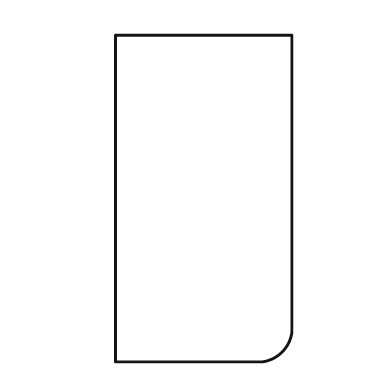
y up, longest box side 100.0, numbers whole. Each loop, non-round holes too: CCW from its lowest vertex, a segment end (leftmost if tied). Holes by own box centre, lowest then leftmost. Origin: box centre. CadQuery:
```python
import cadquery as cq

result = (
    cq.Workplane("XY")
    .moveTo(-27.0, -50.0)
    .lineTo(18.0, -50.0)
    .threePointArc((24.0, -47.0), (27.0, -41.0))
    .lineTo(27.0, 50.0)
    .lineTo(-27.0, 50.0)
    .close()
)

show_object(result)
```